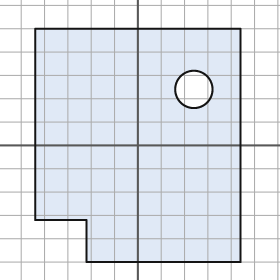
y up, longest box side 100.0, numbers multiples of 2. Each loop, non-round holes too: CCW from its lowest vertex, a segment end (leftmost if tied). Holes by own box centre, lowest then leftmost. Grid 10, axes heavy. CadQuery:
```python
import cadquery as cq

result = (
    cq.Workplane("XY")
    .moveTo(-22.0, -50.0)
    .lineTo(44.0, -50.0)
    .lineTo(44.0, 50.0)
    .lineTo(-44.0, 50.0)
    .lineTo(-44.0, -32.0)
    .lineTo(-22.0, -32.0)
    .close()
    .moveTo(24.0, 24.0)
    .circle(8.0)
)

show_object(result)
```